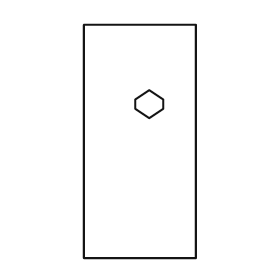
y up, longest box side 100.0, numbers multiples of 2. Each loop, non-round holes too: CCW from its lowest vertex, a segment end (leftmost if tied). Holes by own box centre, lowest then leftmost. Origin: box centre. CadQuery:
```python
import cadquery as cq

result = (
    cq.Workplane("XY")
    .moveTo(-24.0, -50.0)
    .lineTo(24.0, -50.0)
    .lineTo(24.0, 50.0)
    .lineTo(-24.0, 50.0)
    .close()
    .moveTo(4.0, 10.0)
    .lineTo(10.0, 14.0)
    .lineTo(10.0, 18.0)
    .lineTo(4.0, 22.0)
    .lineTo(-2.0, 18.0)
    .lineTo(-2.0, 14.0)
    .close()
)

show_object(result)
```